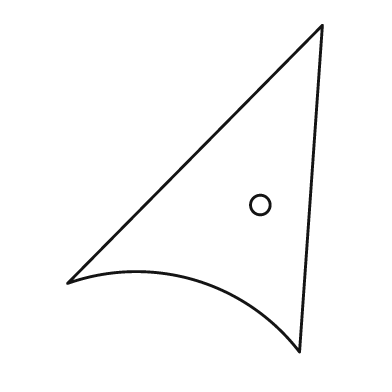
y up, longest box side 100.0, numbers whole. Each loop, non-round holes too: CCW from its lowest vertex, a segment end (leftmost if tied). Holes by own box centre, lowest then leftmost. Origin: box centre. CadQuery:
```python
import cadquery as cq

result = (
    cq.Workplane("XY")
    .moveTo(32.0, -50.0)
    .lineTo(39.0, 50.0)
    .lineTo(-39.0, -29.0)
    .threePointArc((0.0, -28.0), (32.0, -50.0))
    .close()
    .moveTo(20.0, -5.0)
    .circle(3.0)
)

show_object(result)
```